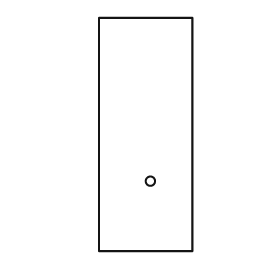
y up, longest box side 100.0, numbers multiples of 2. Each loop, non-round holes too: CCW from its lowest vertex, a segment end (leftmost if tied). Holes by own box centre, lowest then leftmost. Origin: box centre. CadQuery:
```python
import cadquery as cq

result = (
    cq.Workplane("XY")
    .moveTo(-20.0, -50.0)
    .lineTo(20.0, -50.0)
    .lineTo(20.0, 50.0)
    .lineTo(-20.0, 50.0)
    .close()
    .moveTo(2.0, -20.0)
    .circle(2.0)
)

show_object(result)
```